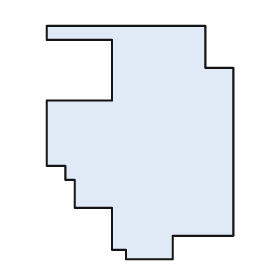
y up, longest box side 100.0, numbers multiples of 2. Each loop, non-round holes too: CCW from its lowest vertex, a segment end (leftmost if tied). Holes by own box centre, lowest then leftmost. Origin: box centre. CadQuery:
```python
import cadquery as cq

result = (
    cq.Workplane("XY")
    .moveTo(-6.0, -50.0)
    .lineTo(14.0, -50.0)
    .lineTo(14.0, -40.0)
    .lineTo(40.0, -40.0)
    .lineTo(40.0, 32.0)
    .lineTo(28.0, 32.0)
    .lineTo(28.0, 50.0)
    .lineTo(-40.0, 50.0)
    .lineTo(-40.0, 44.0)
    .lineTo(-12.0, 44.0)
    .lineTo(-12.0, 18.0)
    .lineTo(-40.0, 18.0)
    .lineTo(-40.0, -10.0)
    .lineTo(-32.0, -10.0)
    .lineTo(-32.0, -16.0)
    .lineTo(-28.0, -16.0)
    .lineTo(-28.0, -28.0)
    .lineTo(-12.0, -28.0)
    .lineTo(-12.0, -46.0)
    .lineTo(-6.0, -46.0)
    .close()
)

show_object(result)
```